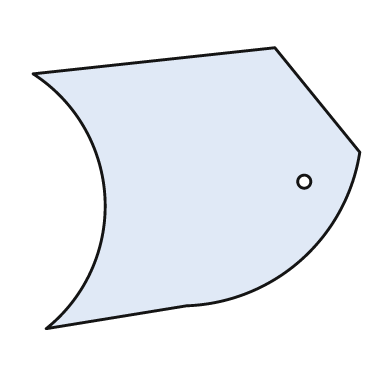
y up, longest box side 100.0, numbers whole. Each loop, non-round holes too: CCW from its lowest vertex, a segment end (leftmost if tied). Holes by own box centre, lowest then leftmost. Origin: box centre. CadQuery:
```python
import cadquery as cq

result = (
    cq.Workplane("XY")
    .moveTo(-46.0, -43.0)
    .lineTo(-3.0, -36.0)
    .threePointArc((32.0, -22.0), (50.0, 11.0))
    .lineTo(24.0, 43.0)
    .lineTo(-50.0, 35.0)
    .threePointArc((-28.0, -3.0), (-46.0, -43.0))
    .close()
    .moveTo(33.0, 2.0)
    .circle(2.0)
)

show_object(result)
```